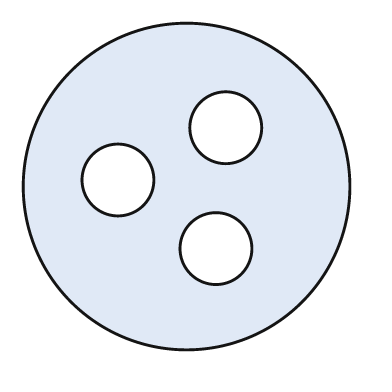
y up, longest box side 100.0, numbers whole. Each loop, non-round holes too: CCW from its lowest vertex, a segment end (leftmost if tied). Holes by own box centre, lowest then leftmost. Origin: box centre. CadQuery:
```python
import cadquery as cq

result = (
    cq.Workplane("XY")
    .moveTo(0.0, 0.0)
    .circle(50.0)
    .moveTo(9.0, -19.0)
    .circle(11.0)
    .moveTo(-21.0, 2.0)
    .circle(11.0)
    .moveTo(12.0, 18.0)
    .circle(11.0)
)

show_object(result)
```